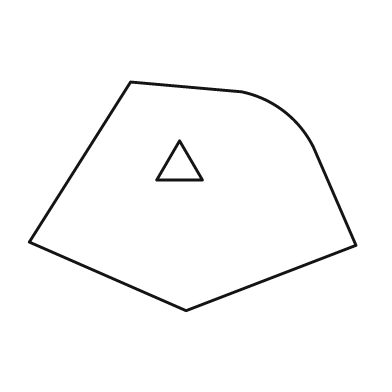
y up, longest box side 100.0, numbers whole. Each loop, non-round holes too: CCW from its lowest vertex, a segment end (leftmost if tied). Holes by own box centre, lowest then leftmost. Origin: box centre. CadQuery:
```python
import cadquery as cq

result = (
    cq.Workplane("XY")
    .moveTo(-2.0, -35.0)
    .lineTo(50.0, -15.0)
    .lineTo(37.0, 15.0)
    .threePointArc((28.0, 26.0), (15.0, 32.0))
    .lineTo(-19.0, 35.0)
    .lineTo(-50.0, -14.0)
    .close()
    .moveTo(-11.0, 5.0)
    .lineTo(3.0, 5.0)
    .lineTo(-4.0, 17.0)
    .close()
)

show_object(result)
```